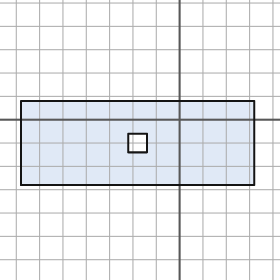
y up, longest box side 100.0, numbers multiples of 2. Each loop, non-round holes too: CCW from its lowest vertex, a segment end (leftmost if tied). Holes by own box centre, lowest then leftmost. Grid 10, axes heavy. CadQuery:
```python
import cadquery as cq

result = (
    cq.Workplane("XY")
    .moveTo(-68.0, -28.0)
    .lineTo(32.0, -28.0)
    .lineTo(32.0, 8.0)
    .lineTo(-68.0, 8.0)
    .close()
    .moveTo(-22.0, -14.0)
    .lineTo(-14.0, -14.0)
    .lineTo(-14.0, -6.0)
    .lineTo(-22.0, -6.0)
    .close()
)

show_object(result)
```